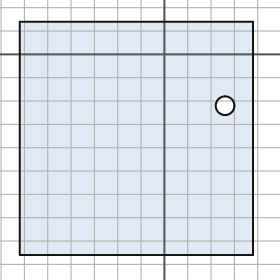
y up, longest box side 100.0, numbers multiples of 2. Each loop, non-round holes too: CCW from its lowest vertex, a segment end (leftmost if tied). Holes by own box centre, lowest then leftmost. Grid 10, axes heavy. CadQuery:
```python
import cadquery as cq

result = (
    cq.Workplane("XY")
    .moveTo(-62.0, -86.0)
    .lineTo(38.0, -86.0)
    .lineTo(38.0, 14.0)
    .lineTo(-62.0, 14.0)
    .close()
    .moveTo(26.0, -22.0)
    .circle(4.0)
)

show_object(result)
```